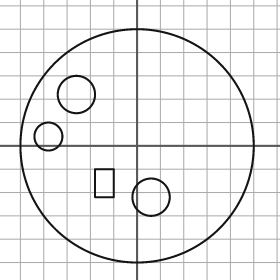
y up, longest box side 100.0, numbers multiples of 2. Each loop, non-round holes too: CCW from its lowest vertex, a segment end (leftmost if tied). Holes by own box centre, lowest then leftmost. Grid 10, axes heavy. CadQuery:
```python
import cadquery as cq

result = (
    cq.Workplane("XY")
    .moveTo(0.0, 0.0)
    .circle(50.0)
    .moveTo(6.0, -22.0)
    .circle(8.0)
    .moveTo(-18.0, -22.0)
    .lineTo(-10.0, -22.0)
    .lineTo(-10.0, -10.0)
    .lineTo(-18.0, -10.0)
    .close()
    .moveTo(-38.0, 4.0)
    .circle(6.0)
    .moveTo(-26.0, 22.0)
    .circle(8.0)
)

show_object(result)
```